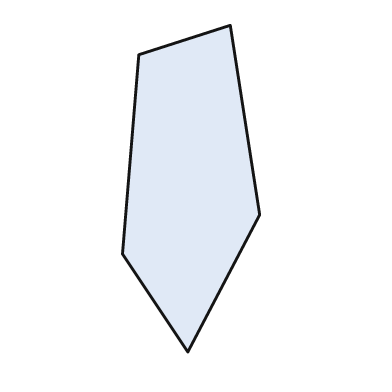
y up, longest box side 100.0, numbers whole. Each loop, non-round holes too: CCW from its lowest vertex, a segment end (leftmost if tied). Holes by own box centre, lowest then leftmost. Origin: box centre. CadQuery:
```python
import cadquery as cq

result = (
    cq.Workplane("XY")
    .moveTo(-1.0, -50.0)
    .lineTo(21.0, -8.0)
    .lineTo(12.0, 50.0)
    .lineTo(-16.0, 41.0)
    .lineTo(-21.0, -20.0)
    .close()
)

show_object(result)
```